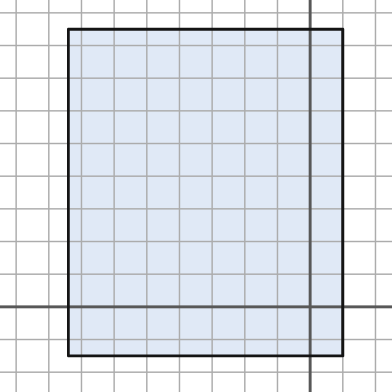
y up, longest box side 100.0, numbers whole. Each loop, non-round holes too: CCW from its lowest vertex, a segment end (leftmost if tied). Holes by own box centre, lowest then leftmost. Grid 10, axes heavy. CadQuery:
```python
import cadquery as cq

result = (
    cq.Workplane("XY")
    .moveTo(-74.0, -15.0)
    .lineTo(10.0, -15.0)
    .lineTo(10.0, 85.0)
    .lineTo(-74.0, 85.0)
    .close()
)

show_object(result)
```